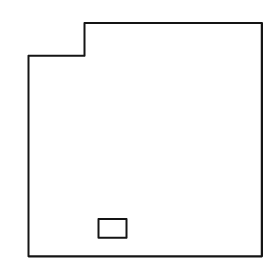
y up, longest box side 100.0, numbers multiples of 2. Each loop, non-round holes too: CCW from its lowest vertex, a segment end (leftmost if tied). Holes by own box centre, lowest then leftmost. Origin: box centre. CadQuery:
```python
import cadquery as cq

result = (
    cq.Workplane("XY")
    .moveTo(-50.0, -50.0)
    .lineTo(50.0, -50.0)
    .lineTo(50.0, 50.0)
    .lineTo(-26.0, 50.0)
    .lineTo(-26.0, 36.0)
    .lineTo(-50.0, 36.0)
    .close()
    .moveTo(-20.0, -42.0)
    .lineTo(-8.0, -42.0)
    .lineTo(-8.0, -34.0)
    .lineTo(-20.0, -34.0)
    .close()
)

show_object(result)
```